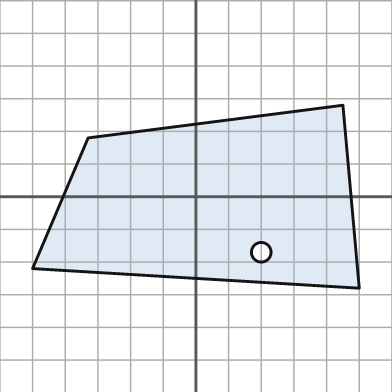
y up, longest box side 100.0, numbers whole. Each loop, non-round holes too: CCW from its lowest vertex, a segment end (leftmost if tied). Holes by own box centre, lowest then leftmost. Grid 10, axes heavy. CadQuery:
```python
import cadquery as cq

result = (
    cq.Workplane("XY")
    .moveTo(50.0, -28.0)
    .lineTo(45.0, 28.0)
    .lineTo(-33.0, 18.0)
    .lineTo(-50.0, -22.0)
    .close()
    .moveTo(20.0, -17.0)
    .circle(3.0)
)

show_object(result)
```